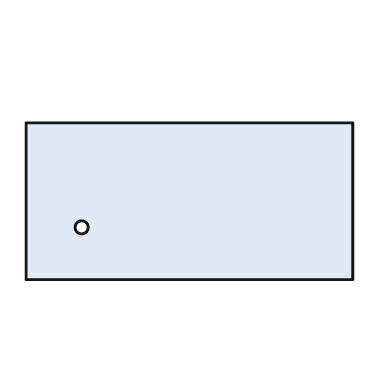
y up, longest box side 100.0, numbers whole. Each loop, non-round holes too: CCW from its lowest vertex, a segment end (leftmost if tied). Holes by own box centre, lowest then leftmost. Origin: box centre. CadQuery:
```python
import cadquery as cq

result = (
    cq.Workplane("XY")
    .moveTo(-50.0, -24.0)
    .lineTo(50.0, -24.0)
    .lineTo(50.0, 24.0)
    .lineTo(-50.0, 24.0)
    .close()
    .moveTo(-33.0, -8.0)
    .circle(2.0)
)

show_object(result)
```